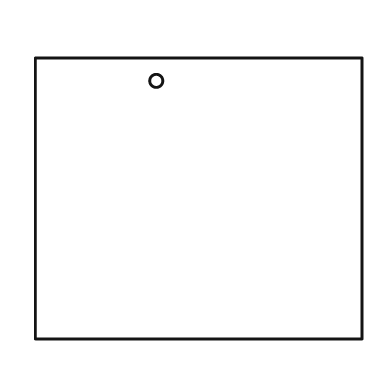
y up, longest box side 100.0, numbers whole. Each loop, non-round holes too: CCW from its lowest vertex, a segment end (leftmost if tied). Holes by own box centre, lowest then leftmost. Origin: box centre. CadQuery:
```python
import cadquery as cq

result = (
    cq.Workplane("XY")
    .moveTo(-50.0, -43.0)
    .lineTo(50.0, -43.0)
    .lineTo(50.0, 43.0)
    .lineTo(-50.0, 43.0)
    .close()
    .moveTo(-13.0, 36.0)
    .circle(2.0)
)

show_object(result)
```